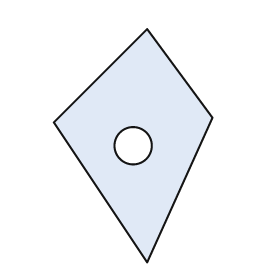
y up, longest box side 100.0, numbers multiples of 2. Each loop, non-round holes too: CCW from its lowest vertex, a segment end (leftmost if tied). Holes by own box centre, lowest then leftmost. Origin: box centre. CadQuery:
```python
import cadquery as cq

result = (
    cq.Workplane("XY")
    .moveTo(6.0, -50.0)
    .lineTo(34.0, 12.0)
    .lineTo(6.0, 50.0)
    .lineTo(-34.0, 10.0)
    .close()
    .moveTo(0.0, 0.0)
    .circle(8.0)
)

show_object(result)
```